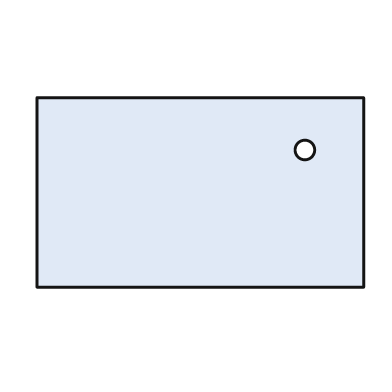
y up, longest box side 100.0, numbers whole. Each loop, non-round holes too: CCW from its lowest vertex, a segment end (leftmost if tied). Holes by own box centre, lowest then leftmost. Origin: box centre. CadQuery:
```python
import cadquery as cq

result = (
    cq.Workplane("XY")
    .moveTo(-50.0, -29.0)
    .lineTo(50.0, -29.0)
    .lineTo(50.0, 29.0)
    .lineTo(-50.0, 29.0)
    .close()
    .moveTo(32.0, 13.0)
    .circle(3.0)
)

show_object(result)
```